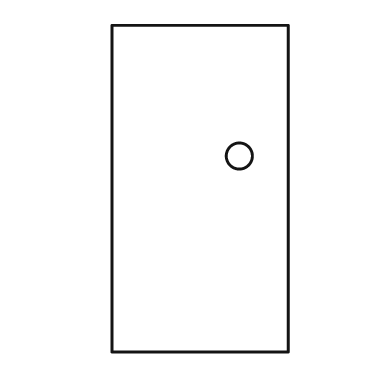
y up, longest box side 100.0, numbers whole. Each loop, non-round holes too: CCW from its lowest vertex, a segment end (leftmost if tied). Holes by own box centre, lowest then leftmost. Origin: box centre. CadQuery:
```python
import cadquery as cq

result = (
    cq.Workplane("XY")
    .moveTo(-27.0, -50.0)
    .lineTo(27.0, -50.0)
    .lineTo(27.0, 50.0)
    .lineTo(-27.0, 50.0)
    .close()
    .moveTo(12.0, 10.0)
    .circle(4.0)
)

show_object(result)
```